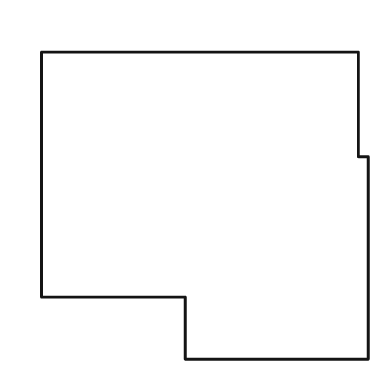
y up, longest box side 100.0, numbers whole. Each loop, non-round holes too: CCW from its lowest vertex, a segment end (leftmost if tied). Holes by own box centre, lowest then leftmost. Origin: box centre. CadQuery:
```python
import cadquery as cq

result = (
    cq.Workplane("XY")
    .moveTo(-6.0, -47.0)
    .lineTo(50.0, -47.0)
    .lineTo(50.0, 15.0)
    .lineTo(47.0, 15.0)
    .lineTo(47.0, 47.0)
    .lineTo(-50.0, 47.0)
    .lineTo(-50.0, -28.0)
    .lineTo(-6.0, -28.0)
    .close()
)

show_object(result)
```